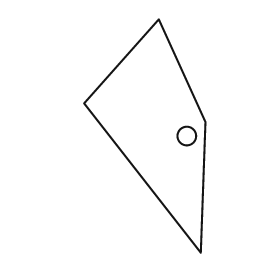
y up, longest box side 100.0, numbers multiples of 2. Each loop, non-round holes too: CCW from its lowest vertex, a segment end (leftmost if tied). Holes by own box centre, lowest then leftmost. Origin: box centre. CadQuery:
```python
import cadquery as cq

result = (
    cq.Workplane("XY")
    .moveTo(24.0, -50.0)
    .lineTo(26.0, 6.0)
    .lineTo(6.0, 50.0)
    .lineTo(-26.0, 14.0)
    .close()
    .moveTo(18.0, 0.0)
    .circle(4.0)
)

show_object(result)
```